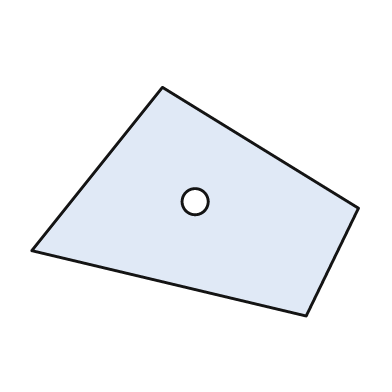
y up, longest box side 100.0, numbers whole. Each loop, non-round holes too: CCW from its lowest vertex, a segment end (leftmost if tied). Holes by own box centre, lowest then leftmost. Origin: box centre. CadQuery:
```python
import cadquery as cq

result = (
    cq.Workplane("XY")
    .moveTo(34.0, -35.0)
    .lineTo(50.0, -2.0)
    .lineTo(-10.0, 35.0)
    .lineTo(-50.0, -15.0)
    .close()
    .moveTo(0.0, 0.0)
    .circle(4.0)
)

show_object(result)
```